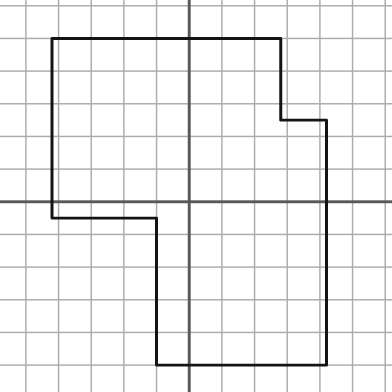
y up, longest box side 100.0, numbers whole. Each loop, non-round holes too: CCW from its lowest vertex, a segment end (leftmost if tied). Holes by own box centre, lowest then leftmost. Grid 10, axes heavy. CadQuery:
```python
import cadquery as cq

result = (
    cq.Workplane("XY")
    .moveTo(-10.0, -50.0)
    .lineTo(42.0, -50.0)
    .lineTo(42.0, 25.0)
    .lineTo(28.0, 25.0)
    .lineTo(28.0, 50.0)
    .lineTo(-42.0, 50.0)
    .lineTo(-42.0, -5.0)
    .lineTo(-10.0, -5.0)
    .close()
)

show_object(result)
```